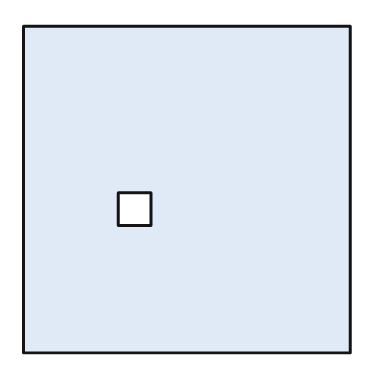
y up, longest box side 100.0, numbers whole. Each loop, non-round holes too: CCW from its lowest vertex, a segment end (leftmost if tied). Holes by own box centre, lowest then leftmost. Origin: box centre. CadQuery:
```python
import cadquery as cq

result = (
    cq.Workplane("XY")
    .moveTo(-50.0, -50.0)
    .lineTo(50.0, -50.0)
    .lineTo(50.0, 50.0)
    .lineTo(-50.0, 50.0)
    .close()
    .moveTo(-21.0, -11.0)
    .lineTo(-11.0, -11.0)
    .lineTo(-11.0, -1.0)
    .lineTo(-21.0, -1.0)
    .close()
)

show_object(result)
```